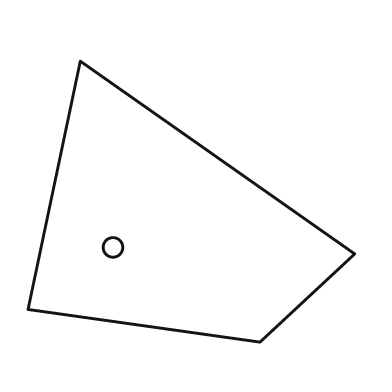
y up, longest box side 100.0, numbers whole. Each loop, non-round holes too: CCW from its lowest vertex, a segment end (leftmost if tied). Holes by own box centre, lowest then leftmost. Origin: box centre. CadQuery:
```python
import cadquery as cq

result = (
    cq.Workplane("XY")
    .moveTo(21.0, -43.0)
    .lineTo(50.0, -16.0)
    .lineTo(-34.0, 43.0)
    .lineTo(-50.0, -33.0)
    .close()
    .moveTo(-24.0, -14.0)
    .circle(3.0)
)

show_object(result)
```